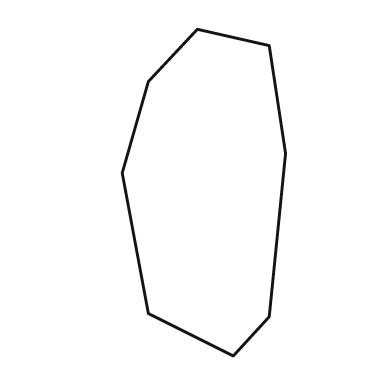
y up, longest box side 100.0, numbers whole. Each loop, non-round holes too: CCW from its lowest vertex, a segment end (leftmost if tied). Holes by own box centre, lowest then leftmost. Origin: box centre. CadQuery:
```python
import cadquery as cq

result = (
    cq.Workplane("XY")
    .moveTo(9.0, -50.0)
    .lineTo(20.0, -38.0)
    .lineTo(25.0, 12.0)
    .lineTo(20.0, 45.0)
    .lineTo(-2.0, 50.0)
    .lineTo(-17.0, 34.0)
    .lineTo(-25.0, 6.0)
    .lineTo(-17.0, -37.0)
    .close()
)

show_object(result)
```